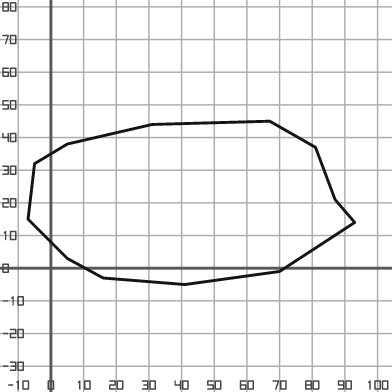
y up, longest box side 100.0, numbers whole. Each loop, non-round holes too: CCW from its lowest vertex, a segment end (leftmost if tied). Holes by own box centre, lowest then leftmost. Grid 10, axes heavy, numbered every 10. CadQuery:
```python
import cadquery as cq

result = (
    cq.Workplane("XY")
    .moveTo(41.0, -5.0)
    .lineTo(70.0, -1.0)
    .lineTo(93.0, 14.0)
    .lineTo(87.0, 21.0)
    .lineTo(81.0, 37.0)
    .lineTo(67.0, 45.0)
    .lineTo(31.0, 44.0)
    .lineTo(5.0, 38.0)
    .lineTo(-5.0, 32.0)
    .lineTo(-7.0, 15.0)
    .lineTo(5.0, 3.0)
    .lineTo(16.0, -3.0)
    .close()
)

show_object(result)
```